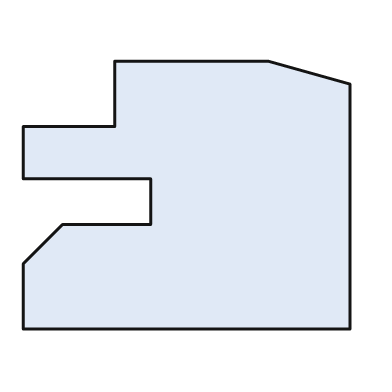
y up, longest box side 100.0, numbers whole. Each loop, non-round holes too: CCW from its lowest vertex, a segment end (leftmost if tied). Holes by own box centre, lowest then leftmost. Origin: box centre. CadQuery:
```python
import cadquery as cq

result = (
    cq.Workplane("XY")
    .moveTo(-50.0, -41.0)
    .lineTo(50.0, -41.0)
    .lineTo(50.0, 34.0)
    .lineTo(25.0, 41.0)
    .lineTo(-22.0, 41.0)
    .lineTo(-22.0, 21.0)
    .lineTo(-50.0, 21.0)
    .lineTo(-50.0, 5.0)
    .lineTo(-11.0, 5.0)
    .lineTo(-11.0, -9.0)
    .lineTo(-38.0, -9.0)
    .lineTo(-50.0, -21.0)
    .close()
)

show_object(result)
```